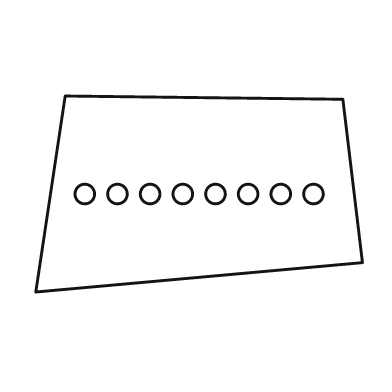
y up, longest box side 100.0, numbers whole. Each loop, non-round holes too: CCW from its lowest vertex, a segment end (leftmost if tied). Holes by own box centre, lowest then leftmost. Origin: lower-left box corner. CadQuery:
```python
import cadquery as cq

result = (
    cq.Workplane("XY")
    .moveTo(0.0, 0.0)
    .lineTo(100.0, 9.0)
    .lineTo(94.0, 59.0)
    .lineTo(9.0, 60.0)
    .close()
    .moveTo(15.0, 30.0)
    .circle(3.0)
    .moveTo(25.0, 30.0)
    .circle(3.0)
    .moveTo(35.0, 30.0)
    .circle(3.0)
    .moveTo(45.0, 30.0)
    .circle(3.0)
    .moveTo(55.0, 30.0)
    .circle(3.0)
    .moveTo(65.0, 30.0)
    .circle(3.0)
    .moveTo(75.0, 30.0)
    .circle(3.0)
    .moveTo(85.0, 30.0)
    .circle(3.0)
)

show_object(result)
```